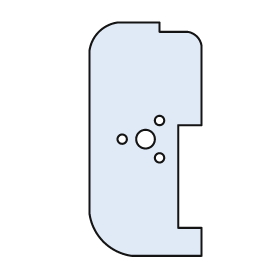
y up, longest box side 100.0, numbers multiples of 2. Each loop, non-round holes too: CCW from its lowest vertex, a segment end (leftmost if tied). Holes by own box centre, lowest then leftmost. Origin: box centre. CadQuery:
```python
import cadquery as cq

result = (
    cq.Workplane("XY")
    .moveTo(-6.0, -50.0)
    .lineTo(24.0, -50.0)
    .lineTo(24.0, -38.0)
    .lineTo(14.0, -38.0)
    .lineTo(14.0, 6.0)
    .lineTo(24.0, 6.0)
    .lineTo(24.0, 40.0)
    .threePointArc((22.0, 44.0), (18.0, 46.0))
    .lineTo(6.0, 46.0)
    .lineTo(6.0, 50.0)
    .lineTo(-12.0, 50.0)
    .threePointArc((-20.0, 46.0), (-24.0, 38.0))
    .lineTo(-24.0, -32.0)
    .threePointArc((-18.0, -44.0), (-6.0, -50.0))
    .close()
    .moveTo(6.0, -8.0)
    .circle(2.0)
    .moveTo(-10.0, 0.0)
    .circle(2.0)
    .moveTo(0.0, 0.0)
    .circle(4.0)
    .moveTo(6.0, 8.0)
    .circle(2.0)
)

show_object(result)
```